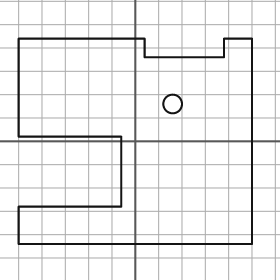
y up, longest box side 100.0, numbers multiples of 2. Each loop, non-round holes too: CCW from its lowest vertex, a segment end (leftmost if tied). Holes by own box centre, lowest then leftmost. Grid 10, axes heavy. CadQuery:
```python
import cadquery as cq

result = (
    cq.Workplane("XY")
    .moveTo(-50.0, -44.0)
    .lineTo(50.0, -44.0)
    .lineTo(50.0, 44.0)
    .lineTo(38.0, 44.0)
    .lineTo(38.0, 36.0)
    .lineTo(4.0, 36.0)
    .lineTo(4.0, 44.0)
    .lineTo(-50.0, 44.0)
    .lineTo(-50.0, 2.0)
    .lineTo(-6.0, 2.0)
    .lineTo(-6.0, -28.0)
    .lineTo(-50.0, -28.0)
    .close()
    .moveTo(16.0, 16.0)
    .circle(4.0)
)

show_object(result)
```